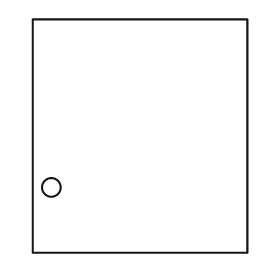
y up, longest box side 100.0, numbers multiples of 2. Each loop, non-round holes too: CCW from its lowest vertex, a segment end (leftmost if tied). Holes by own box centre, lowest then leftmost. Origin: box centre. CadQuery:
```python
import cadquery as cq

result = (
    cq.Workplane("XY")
    .moveTo(-46.0, -50.0)
    .lineTo(46.0, -50.0)
    .lineTo(46.0, 50.0)
    .lineTo(-46.0, 50.0)
    .close()
    .moveTo(-38.0, -22.0)
    .circle(4.0)
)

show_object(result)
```